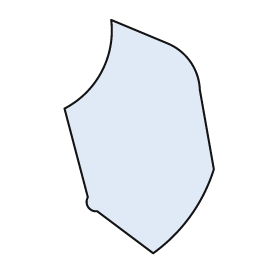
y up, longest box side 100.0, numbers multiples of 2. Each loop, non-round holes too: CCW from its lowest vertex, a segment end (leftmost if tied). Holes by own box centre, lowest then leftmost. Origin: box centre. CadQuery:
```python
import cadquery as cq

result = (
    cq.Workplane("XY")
    .moveTo(6.0, -50.0)
    .threePointArc((22.0, -34.0), (32.0, -14.0))
    .lineTo(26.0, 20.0)
    .threePointArc((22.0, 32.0), (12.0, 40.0))
    .lineTo(-12.0, 50.0)
    .threePointArc((-16.0, 28.0), (-32.0, 12.0))
    .lineTo(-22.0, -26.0)
    .threePointArc((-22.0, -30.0), (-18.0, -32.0))
    .close()
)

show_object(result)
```